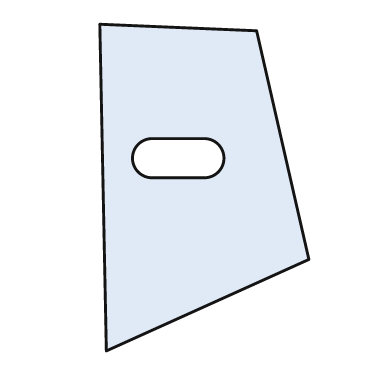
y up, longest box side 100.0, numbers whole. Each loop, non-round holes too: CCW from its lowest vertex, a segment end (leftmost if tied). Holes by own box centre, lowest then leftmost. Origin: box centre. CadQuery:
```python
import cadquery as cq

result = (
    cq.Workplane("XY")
    .moveTo(-30.0, -50.0)
    .lineTo(32.0, -22.0)
    .lineTo(16.0, 48.0)
    .lineTo(-32.0, 50.0)
    .close()
    .moveTo(-16.0, 3.0)
    .lineTo(0.0, 3.0)
    .threePointArc((6.0, 9.0), (0.0, 15.0))
    .lineTo(-16.0, 15.0)
    .threePointArc((-22.0, 9.0), (-16.0, 3.0))
    .close()
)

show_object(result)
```